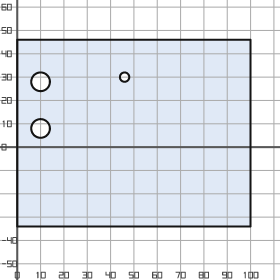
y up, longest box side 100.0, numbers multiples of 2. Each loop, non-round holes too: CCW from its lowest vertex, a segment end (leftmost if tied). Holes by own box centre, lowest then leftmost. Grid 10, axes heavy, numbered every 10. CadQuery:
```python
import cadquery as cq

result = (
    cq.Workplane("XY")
    .moveTo(0.0, -34.0)
    .lineTo(100.0, -34.0)
    .lineTo(100.0, 46.0)
    .lineTo(0.0, 46.0)
    .close()
    .moveTo(10.0, 8.0)
    .circle(4.0)
    .moveTo(10.0, 28.0)
    .circle(4.0)
    .moveTo(46.0, 30.0)
    .circle(2.0)
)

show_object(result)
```